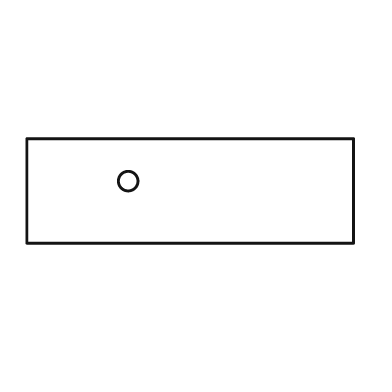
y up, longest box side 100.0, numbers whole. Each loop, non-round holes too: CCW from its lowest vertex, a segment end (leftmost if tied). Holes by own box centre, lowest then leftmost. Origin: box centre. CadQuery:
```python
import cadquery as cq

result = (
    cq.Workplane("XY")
    .moveTo(-50.0, -16.0)
    .lineTo(50.0, -16.0)
    .lineTo(50.0, 16.0)
    .lineTo(-50.0, 16.0)
    .close()
    .moveTo(-19.0, 3.0)
    .circle(3.0)
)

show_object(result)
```